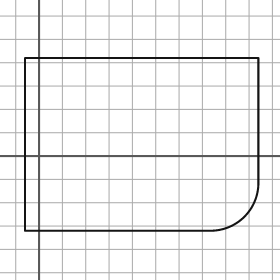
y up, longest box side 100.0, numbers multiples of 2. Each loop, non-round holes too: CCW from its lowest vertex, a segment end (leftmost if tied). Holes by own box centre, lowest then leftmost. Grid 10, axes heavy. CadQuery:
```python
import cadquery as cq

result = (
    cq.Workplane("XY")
    .moveTo(-6.0, -32.0)
    .lineTo(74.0, -32.0)
    .threePointArc((88.0, -26.0), (94.0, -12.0))
    .lineTo(94.0, 42.0)
    .lineTo(-6.0, 42.0)
    .close()
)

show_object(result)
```